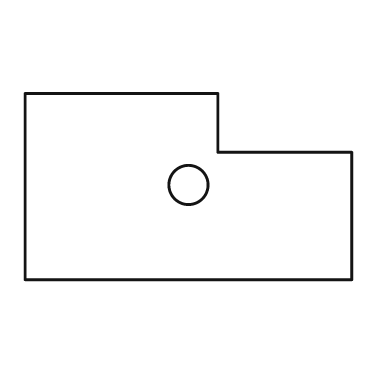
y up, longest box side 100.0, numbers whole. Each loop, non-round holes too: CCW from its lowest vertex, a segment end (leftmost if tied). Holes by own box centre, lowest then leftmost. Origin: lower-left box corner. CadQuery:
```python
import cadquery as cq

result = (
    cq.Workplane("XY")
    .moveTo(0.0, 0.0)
    .lineTo(100.0, 0.0)
    .lineTo(100.0, 39.0)
    .lineTo(59.0, 39.0)
    .lineTo(59.0, 57.0)
    .lineTo(0.0, 57.0)
    .close()
    .moveTo(50.0, 29.0)
    .circle(6.0)
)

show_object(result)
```